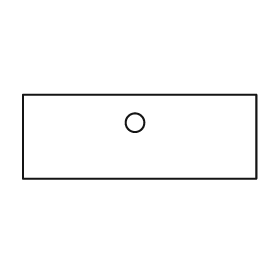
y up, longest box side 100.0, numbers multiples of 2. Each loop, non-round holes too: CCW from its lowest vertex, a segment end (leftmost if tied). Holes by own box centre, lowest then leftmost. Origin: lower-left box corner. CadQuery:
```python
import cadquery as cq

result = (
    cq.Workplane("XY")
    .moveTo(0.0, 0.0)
    .lineTo(100.0, 0.0)
    .lineTo(100.0, 36.0)
    .lineTo(0.0, 36.0)
    .close()
    .moveTo(48.0, 24.0)
    .circle(4.0)
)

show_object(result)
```